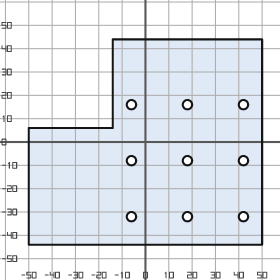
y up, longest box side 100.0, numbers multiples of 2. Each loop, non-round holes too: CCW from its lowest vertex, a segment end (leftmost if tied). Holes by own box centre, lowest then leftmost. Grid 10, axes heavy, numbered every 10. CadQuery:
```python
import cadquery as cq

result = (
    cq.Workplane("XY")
    .moveTo(-50.0, -44.0)
    .lineTo(50.0, -44.0)
    .lineTo(50.0, 44.0)
    .lineTo(-14.0, 44.0)
    .lineTo(-14.0, 6.0)
    .lineTo(-50.0, 6.0)
    .close()
    .moveTo(-6.0, -32.0)
    .circle(2.0)
    .moveTo(18.0, -32.0)
    .circle(2.0)
    .moveTo(42.0, -32.0)
    .circle(2.0)
    .moveTo(-6.0, -8.0)
    .circle(2.0)
    .moveTo(18.0, -8.0)
    .circle(2.0)
    .moveTo(42.0, -8.0)
    .circle(2.0)
    .moveTo(-6.0, 16.0)
    .circle(2.0)
    .moveTo(18.0, 16.0)
    .circle(2.0)
    .moveTo(42.0, 16.0)
    .circle(2.0)
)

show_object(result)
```